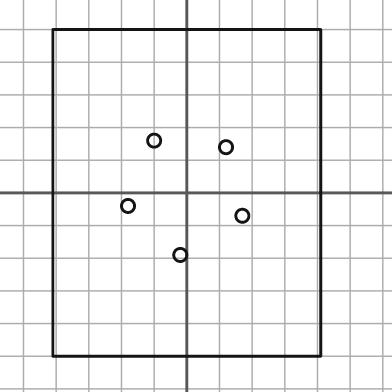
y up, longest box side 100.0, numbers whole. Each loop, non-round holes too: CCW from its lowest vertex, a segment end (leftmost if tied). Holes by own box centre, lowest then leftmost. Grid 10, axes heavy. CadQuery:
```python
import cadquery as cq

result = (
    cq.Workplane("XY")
    .moveTo(-41.0, -50.0)
    .lineTo(41.0, -50.0)
    .lineTo(41.0, 50.0)
    .lineTo(-41.0, 50.0)
    .close()
    .moveTo(-2.0, -19.0)
    .circle(2.0)
    .moveTo(17.0, -7.0)
    .circle(2.0)
    .moveTo(-18.0, -4.0)
    .circle(2.0)
    .moveTo(12.0, 14.0)
    .circle(2.0)
    .moveTo(-10.0, 16.0)
    .circle(2.0)
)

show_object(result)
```